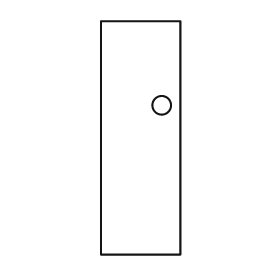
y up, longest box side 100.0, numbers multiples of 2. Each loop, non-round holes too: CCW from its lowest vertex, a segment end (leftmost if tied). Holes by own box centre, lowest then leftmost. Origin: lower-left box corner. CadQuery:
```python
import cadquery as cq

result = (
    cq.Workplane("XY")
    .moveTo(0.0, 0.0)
    .lineTo(34.0, 0.0)
    .lineTo(34.0, 100.0)
    .lineTo(0.0, 100.0)
    .close()
    .moveTo(26.0, 64.0)
    .circle(4.0)
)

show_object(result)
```